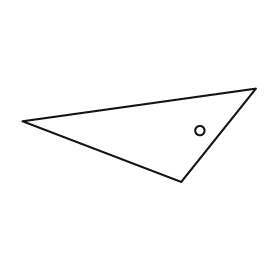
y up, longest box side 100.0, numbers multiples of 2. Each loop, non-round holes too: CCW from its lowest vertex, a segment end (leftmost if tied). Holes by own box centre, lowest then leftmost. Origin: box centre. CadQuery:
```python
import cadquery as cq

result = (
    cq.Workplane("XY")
    .moveTo(18.0, -20.0)
    .lineTo(50.0, 20.0)
    .lineTo(-50.0, 6.0)
    .close()
    .moveTo(26.0, 2.0)
    .circle(2.0)
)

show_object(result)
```